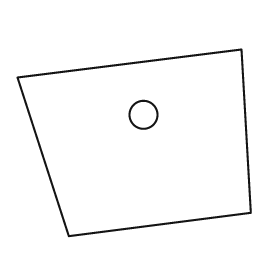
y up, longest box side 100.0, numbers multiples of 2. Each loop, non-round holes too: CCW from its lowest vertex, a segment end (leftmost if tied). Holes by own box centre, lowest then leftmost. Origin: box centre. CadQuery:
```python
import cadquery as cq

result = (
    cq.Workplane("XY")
    .moveTo(-28.0, -40.0)
    .lineTo(50.0, -30.0)
    .lineTo(46.0, 40.0)
    .lineTo(-50.0, 28.0)
    .close()
    .moveTo(4.0, 12.0)
    .circle(6.0)
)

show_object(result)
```